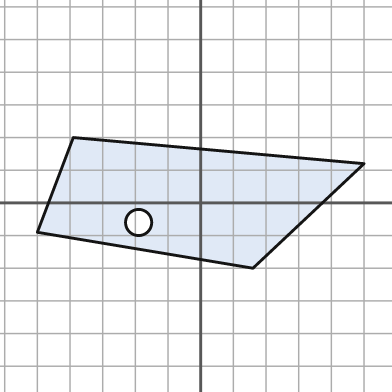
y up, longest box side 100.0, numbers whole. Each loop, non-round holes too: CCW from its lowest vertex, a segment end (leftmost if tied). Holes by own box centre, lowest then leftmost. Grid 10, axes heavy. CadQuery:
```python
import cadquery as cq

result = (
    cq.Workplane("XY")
    .moveTo(16.0, -20.0)
    .lineTo(50.0, 12.0)
    .lineTo(-39.0, 20.0)
    .lineTo(-50.0, -9.0)
    .close()
    .moveTo(-19.0, -6.0)
    .circle(4.0)
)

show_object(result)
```